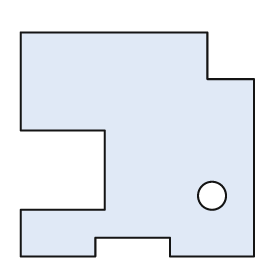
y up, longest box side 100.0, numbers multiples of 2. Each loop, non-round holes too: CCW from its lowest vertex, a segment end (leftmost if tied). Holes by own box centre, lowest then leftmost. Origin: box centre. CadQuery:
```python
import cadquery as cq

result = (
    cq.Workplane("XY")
    .moveTo(-50.0, -48.0)
    .lineTo(-18.0, -48.0)
    .lineTo(-18.0, -40.0)
    .lineTo(14.0, -40.0)
    .lineTo(14.0, -48.0)
    .lineTo(50.0, -48.0)
    .lineTo(50.0, 28.0)
    .lineTo(30.0, 28.0)
    .lineTo(30.0, 48.0)
    .lineTo(-50.0, 48.0)
    .lineTo(-50.0, 6.0)
    .lineTo(-14.0, 6.0)
    .lineTo(-14.0, -28.0)
    .lineTo(-50.0, -28.0)
    .close()
    .moveTo(32.0, -22.0)
    .circle(6.0)
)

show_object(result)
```